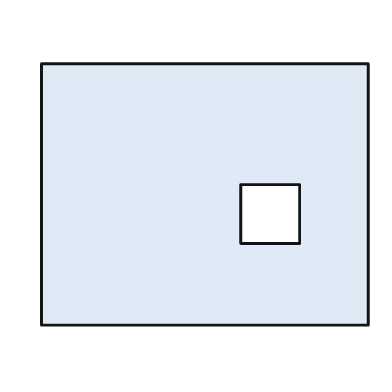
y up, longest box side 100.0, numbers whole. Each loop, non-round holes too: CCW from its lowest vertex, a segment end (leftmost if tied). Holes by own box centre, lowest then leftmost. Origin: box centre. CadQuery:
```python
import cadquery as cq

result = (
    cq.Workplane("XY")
    .moveTo(-50.0, -40.0)
    .lineTo(50.0, -40.0)
    .lineTo(50.0, 40.0)
    .lineTo(-50.0, 40.0)
    .close()
    .moveTo(11.0, -15.0)
    .lineTo(29.0, -15.0)
    .lineTo(29.0, 3.0)
    .lineTo(11.0, 3.0)
    .close()
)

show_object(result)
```